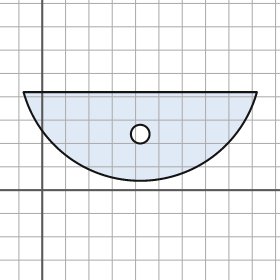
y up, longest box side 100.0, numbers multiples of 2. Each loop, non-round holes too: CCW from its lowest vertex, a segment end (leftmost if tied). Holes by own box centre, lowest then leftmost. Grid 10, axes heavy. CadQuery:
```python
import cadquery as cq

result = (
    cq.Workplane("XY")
    .moveTo(-8.0, 42.0)
    .threePointArc((42.0, 4.0), (92.0, 42.0))
    .close()
    .moveTo(42.0, 24.0)
    .circle(4.0)
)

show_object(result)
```